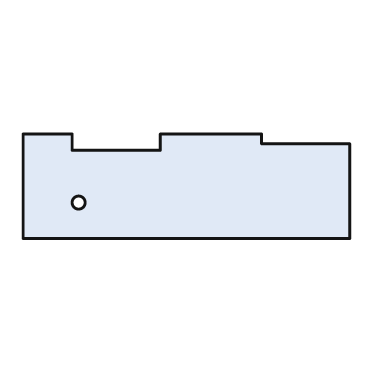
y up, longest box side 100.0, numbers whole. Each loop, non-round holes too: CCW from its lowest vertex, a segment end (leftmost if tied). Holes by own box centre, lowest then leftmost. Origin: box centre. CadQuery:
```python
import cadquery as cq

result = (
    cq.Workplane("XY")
    .moveTo(-50.0, -16.0)
    .lineTo(50.0, -16.0)
    .lineTo(50.0, 13.0)
    .lineTo(23.0, 13.0)
    .lineTo(23.0, 16.0)
    .lineTo(-8.0, 16.0)
    .lineTo(-8.0, 11.0)
    .lineTo(-35.0, 11.0)
    .lineTo(-35.0, 16.0)
    .lineTo(-50.0, 16.0)
    .close()
    .moveTo(-33.0, -5.0)
    .circle(2.0)
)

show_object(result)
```